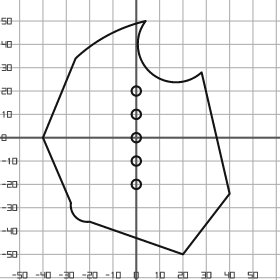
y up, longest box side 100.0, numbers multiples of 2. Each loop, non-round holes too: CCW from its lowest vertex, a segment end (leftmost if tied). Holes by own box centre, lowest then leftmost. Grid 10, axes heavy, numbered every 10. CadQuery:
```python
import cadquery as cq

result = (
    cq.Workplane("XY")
    .moveTo(20.0, -50.0)
    .lineTo(40.0, -24.0)
    .lineTo(28.0, 28.0)
    .threePointArc((6.0, 28.0), (4.0, 50.0))
    .threePointArc((-12.0, 44.0), (-26.0, 34.0))
    .lineTo(-40.0, 0.0)
    .lineTo(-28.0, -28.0)
    .threePointArc((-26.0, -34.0), (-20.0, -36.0))
    .close()
    .moveTo(0.0, -20.0)
    .circle(2.0)
    .moveTo(0.0, -10.0)
    .circle(2.0)
    .moveTo(0.0, 0.0)
    .circle(2.0)
    .moveTo(0.0, 10.0)
    .circle(2.0)
    .moveTo(0.0, 20.0)
    .circle(2.0)
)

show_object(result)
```